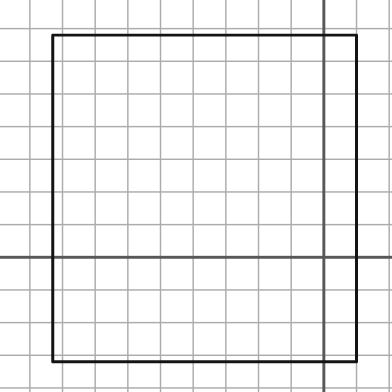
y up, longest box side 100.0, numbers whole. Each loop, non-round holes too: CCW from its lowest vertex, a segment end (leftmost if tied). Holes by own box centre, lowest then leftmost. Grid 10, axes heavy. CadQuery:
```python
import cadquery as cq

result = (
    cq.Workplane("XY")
    .moveTo(-83.0, -32.0)
    .lineTo(10.0, -32.0)
    .lineTo(10.0, 68.0)
    .lineTo(-83.0, 68.0)
    .close()
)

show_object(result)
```